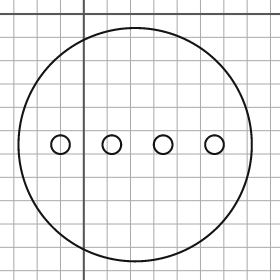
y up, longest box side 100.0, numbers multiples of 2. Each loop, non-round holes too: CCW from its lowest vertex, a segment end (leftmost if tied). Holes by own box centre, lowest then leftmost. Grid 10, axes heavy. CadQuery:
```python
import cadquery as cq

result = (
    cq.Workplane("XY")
    .moveTo(22.0, -56.0)
    .circle(50.0)
    .moveTo(-10.0, -56.0)
    .circle(4.0)
    .moveTo(12.0, -56.0)
    .circle(4.0)
    .moveTo(34.0, -56.0)
    .circle(4.0)
    .moveTo(56.0, -56.0)
    .circle(4.0)
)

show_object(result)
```